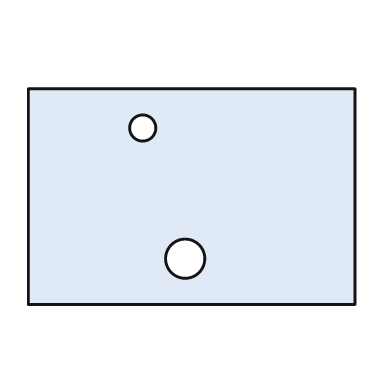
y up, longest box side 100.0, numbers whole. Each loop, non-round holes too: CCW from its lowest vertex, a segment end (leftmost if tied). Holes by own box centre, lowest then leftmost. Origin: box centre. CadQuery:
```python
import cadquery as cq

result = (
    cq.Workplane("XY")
    .moveTo(-50.0, -33.0)
    .lineTo(50.0, -33.0)
    .lineTo(50.0, 33.0)
    .lineTo(-50.0, 33.0)
    .close()
    .moveTo(-2.0, -19.0)
    .circle(6.0)
    .moveTo(-15.0, 21.0)
    .circle(4.0)
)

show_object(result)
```